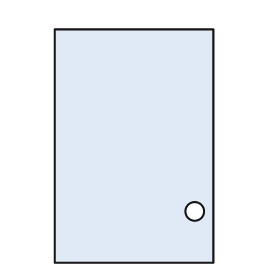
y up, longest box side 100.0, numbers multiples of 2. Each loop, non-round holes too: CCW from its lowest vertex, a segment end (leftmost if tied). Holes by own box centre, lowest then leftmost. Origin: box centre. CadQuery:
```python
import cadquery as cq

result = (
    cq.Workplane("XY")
    .moveTo(-34.0, -50.0)
    .lineTo(34.0, -50.0)
    .lineTo(34.0, 50.0)
    .lineTo(-34.0, 50.0)
    .close()
    .moveTo(26.0, -28.0)
    .circle(4.0)
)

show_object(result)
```